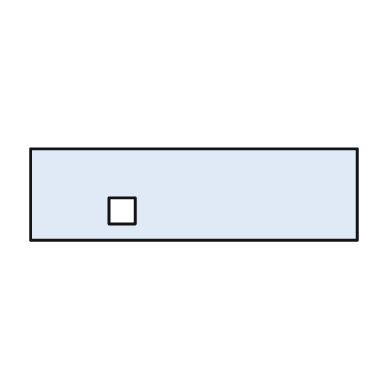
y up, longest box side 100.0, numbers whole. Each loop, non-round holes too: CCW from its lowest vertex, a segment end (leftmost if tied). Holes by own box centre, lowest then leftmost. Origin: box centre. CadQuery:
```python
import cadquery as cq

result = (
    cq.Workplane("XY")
    .moveTo(-50.0, -14.0)
    .lineTo(50.0, -14.0)
    .lineTo(50.0, 14.0)
    .lineTo(-50.0, 14.0)
    .close()
    .moveTo(-26.0, -9.0)
    .lineTo(-18.0, -9.0)
    .lineTo(-18.0, -1.0)
    .lineTo(-26.0, -1.0)
    .close()
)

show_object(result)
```